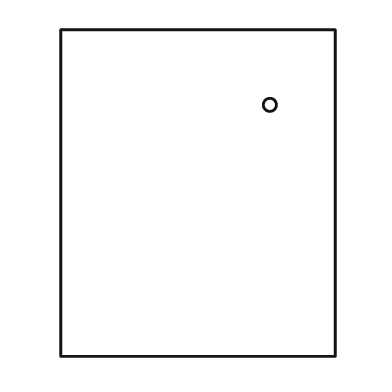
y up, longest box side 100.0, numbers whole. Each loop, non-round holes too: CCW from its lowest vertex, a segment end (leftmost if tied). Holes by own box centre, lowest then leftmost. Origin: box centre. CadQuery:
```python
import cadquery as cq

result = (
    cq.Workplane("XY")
    .moveTo(-42.0, -50.0)
    .lineTo(42.0, -50.0)
    .lineTo(42.0, 50.0)
    .lineTo(-42.0, 50.0)
    .close()
    .moveTo(22.0, 27.0)
    .circle(2.0)
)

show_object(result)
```